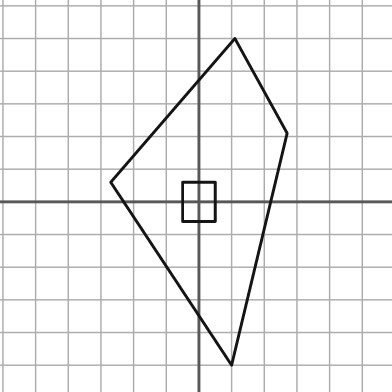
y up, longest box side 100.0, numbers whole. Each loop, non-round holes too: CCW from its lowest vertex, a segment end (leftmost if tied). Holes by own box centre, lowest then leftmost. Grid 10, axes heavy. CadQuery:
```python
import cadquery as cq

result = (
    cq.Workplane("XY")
    .moveTo(10.0, -50.0)
    .lineTo(27.0, 21.0)
    .lineTo(11.0, 50.0)
    .lineTo(-27.0, 6.0)
    .close()
    .moveTo(-5.0, -6.0)
    .lineTo(5.0, -6.0)
    .lineTo(5.0, 6.0)
    .lineTo(-5.0, 6.0)
    .close()
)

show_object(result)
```